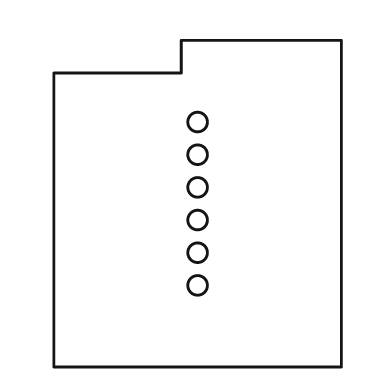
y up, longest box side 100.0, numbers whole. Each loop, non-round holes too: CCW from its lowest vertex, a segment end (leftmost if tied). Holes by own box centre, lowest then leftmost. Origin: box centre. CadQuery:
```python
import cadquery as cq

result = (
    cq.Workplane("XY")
    .moveTo(-44.0, -50.0)
    .lineTo(44.0, -50.0)
    .lineTo(44.0, 50.0)
    .lineTo(-5.0, 50.0)
    .lineTo(-5.0, 40.0)
    .lineTo(-44.0, 40.0)
    .close()
    .moveTo(0.0, -25.0)
    .circle(3.0)
    .moveTo(0.0, -15.0)
    .circle(3.0)
    .moveTo(0.0, -5.0)
    .circle(3.0)
    .moveTo(0.0, 5.0)
    .circle(3.0)
    .moveTo(0.0, 15.0)
    .circle(3.0)
    .moveTo(0.0, 25.0)
    .circle(3.0)
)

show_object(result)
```